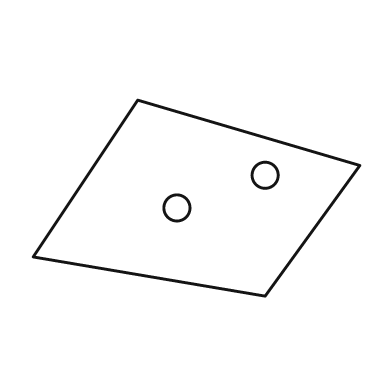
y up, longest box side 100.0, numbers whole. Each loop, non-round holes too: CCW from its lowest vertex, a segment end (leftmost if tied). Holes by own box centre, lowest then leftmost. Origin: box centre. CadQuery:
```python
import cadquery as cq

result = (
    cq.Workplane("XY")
    .moveTo(21.0, -30.0)
    .lineTo(50.0, 10.0)
    .lineTo(-18.0, 30.0)
    .lineTo(-50.0, -18.0)
    .close()
    .moveTo(-6.0, -3.0)
    .circle(4.0)
    .moveTo(21.0, 7.0)
    .circle(4.0)
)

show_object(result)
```